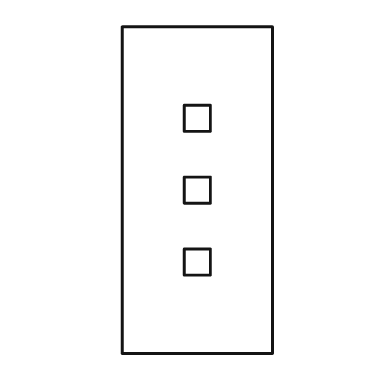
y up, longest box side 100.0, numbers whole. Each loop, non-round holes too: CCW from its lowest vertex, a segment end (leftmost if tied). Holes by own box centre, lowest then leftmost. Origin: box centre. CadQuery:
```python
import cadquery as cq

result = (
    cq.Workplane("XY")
    .moveTo(-23.0, -50.0)
    .lineTo(23.0, -50.0)
    .lineTo(23.0, 50.0)
    .lineTo(-23.0, 50.0)
    .close()
    .moveTo(-4.0, -26.0)
    .lineTo(4.0, -26.0)
    .lineTo(4.0, -18.0)
    .lineTo(-4.0, -18.0)
    .close()
    .moveTo(-4.0, -4.0)
    .lineTo(4.0, -4.0)
    .lineTo(4.0, 4.0)
    .lineTo(-4.0, 4.0)
    .close()
    .moveTo(-4.0, 18.0)
    .lineTo(4.0, 18.0)
    .lineTo(4.0, 26.0)
    .lineTo(-4.0, 26.0)
    .close()
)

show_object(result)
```